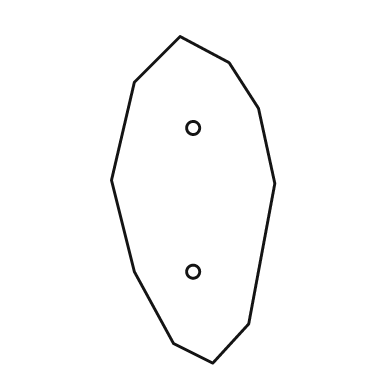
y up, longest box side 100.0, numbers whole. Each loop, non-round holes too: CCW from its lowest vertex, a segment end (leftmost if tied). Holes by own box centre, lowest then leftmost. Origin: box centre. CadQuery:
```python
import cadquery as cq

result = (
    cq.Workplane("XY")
    .moveTo(6.0, -50.0)
    .lineTo(17.0, -38.0)
    .lineTo(25.0, 5.0)
    .lineTo(20.0, 28.0)
    .lineTo(11.0, 42.0)
    .lineTo(-4.0, 50.0)
    .lineTo(-18.0, 36.0)
    .lineTo(-25.0, 6.0)
    .lineTo(-18.0, -22.0)
    .lineTo(-6.0, -44.0)
    .close()
    .moveTo(0.0, -22.0)
    .circle(2.0)
    .moveTo(0.0, 22.0)
    .circle(2.0)
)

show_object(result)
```